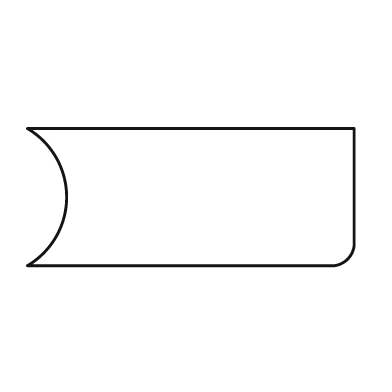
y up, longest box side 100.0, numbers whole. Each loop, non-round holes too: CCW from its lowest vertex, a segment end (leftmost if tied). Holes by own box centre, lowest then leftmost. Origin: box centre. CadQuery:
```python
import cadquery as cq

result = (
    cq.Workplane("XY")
    .moveTo(-50.0, -21.0)
    .lineTo(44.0, -21.0)
    .threePointArc((48.0, -19.0), (50.0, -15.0))
    .lineTo(50.0, 21.0)
    .lineTo(-50.0, 21.0)
    .threePointArc((-38.0, 0.0), (-50.0, -21.0))
    .close()
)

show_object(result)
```